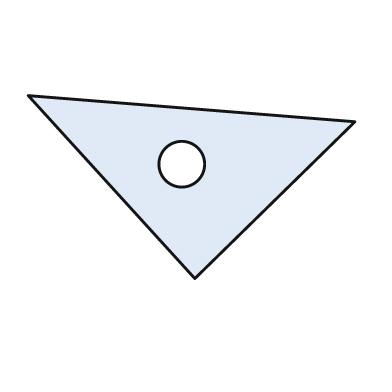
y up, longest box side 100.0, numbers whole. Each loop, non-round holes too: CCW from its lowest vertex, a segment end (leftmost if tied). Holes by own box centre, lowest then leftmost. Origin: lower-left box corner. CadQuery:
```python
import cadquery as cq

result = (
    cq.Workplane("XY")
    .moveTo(51.0, 0.0)
    .lineTo(100.0, 48.0)
    .lineTo(0.0, 56.0)
    .close()
    .moveTo(47.0, 35.0)
    .circle(7.0)
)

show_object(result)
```